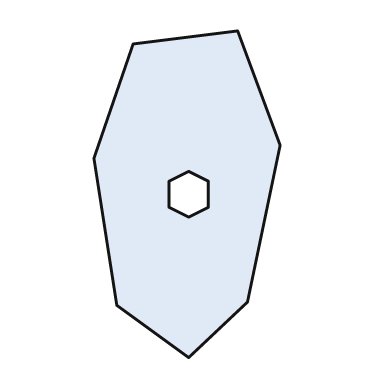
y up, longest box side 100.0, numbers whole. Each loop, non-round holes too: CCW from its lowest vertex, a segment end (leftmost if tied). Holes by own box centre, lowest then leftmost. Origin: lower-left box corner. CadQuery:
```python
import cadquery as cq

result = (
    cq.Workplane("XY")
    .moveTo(29.0, 0.0)
    .lineTo(47.0, 17.0)
    .lineTo(57.0, 65.0)
    .lineTo(44.0, 100.0)
    .lineTo(12.0, 96.0)
    .lineTo(0.0, 61.0)
    .lineTo(7.0, 16.0)
    .close()
    .moveTo(29.0, 43.0)
    .lineTo(35.0, 46.0)
    .lineTo(35.0, 54.0)
    .lineTo(29.0, 57.0)
    .lineTo(23.0, 54.0)
    .lineTo(23.0, 46.0)
    .close()
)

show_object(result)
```